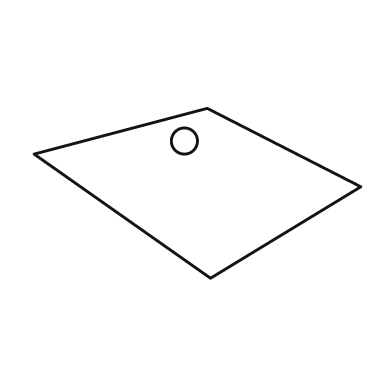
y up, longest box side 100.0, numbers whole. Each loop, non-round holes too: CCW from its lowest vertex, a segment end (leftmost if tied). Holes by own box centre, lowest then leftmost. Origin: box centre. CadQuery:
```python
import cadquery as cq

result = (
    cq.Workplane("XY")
    .moveTo(4.0, -26.0)
    .lineTo(50.0, 2.0)
    .lineTo(3.0, 26.0)
    .lineTo(-50.0, 12.0)
    .close()
    .moveTo(-4.0, 16.0)
    .circle(4.0)
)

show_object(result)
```